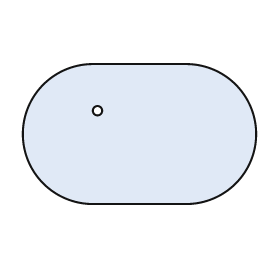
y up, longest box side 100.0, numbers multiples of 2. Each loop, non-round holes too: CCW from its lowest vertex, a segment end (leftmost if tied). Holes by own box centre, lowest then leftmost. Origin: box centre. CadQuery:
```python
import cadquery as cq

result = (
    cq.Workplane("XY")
    .moveTo(-20.0, -30.0)
    .lineTo(20.0, -30.0)
    .threePointArc((50.0, 0.0), (20.0, 30.0))
    .lineTo(-20.0, 30.0)
    .threePointArc((-50.0, 0.0), (-20.0, -30.0))
    .close()
    .moveTo(-18.0, 10.0)
    .circle(2.0)
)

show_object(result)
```